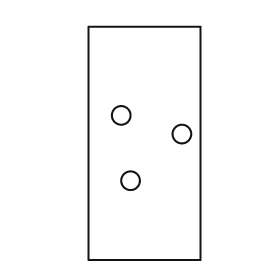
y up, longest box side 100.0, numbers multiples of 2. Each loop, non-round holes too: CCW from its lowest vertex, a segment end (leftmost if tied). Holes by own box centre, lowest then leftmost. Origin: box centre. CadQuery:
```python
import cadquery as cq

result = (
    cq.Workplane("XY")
    .moveTo(-24.0, -50.0)
    .lineTo(24.0, -50.0)
    .lineTo(24.0, 50.0)
    .lineTo(-24.0, 50.0)
    .close()
    .moveTo(-6.0, -16.0)
    .circle(4.0)
    .moveTo(16.0, 4.0)
    .circle(4.0)
    .moveTo(-10.0, 12.0)
    .circle(4.0)
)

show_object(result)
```